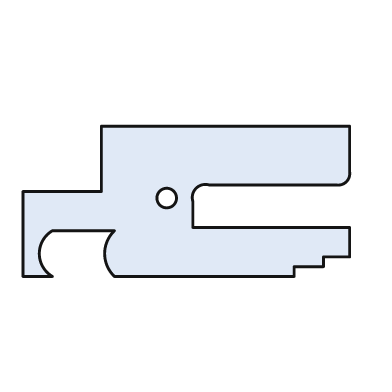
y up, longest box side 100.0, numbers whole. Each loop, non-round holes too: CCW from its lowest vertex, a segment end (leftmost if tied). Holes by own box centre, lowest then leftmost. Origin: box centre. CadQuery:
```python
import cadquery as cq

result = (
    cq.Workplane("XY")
    .moveTo(-50.0, -23.0)
    .lineTo(-41.0, -23.0)
    .threePointArc((-45.0, -16.0), (-41.0, -9.0))
    .lineTo(-22.0, -9.0)
    .threePointArc((-25.0, -16.0), (-22.0, -23.0))
    .lineTo(33.0, -23.0)
    .lineTo(33.0, -20.0)
    .lineTo(42.0, -20.0)
    .lineTo(42.0, -17.0)
    .lineTo(50.0, -17.0)
    .lineTo(50.0, -8.0)
    .lineTo(2.0, -8.0)
    .lineTo(2.0, 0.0)
    .threePointArc((3.0, 4.0), (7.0, 5.0))
    .lineTo(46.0, 5.0)
    .threePointArc((49.0, 6.0), (50.0, 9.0))
    .lineTo(50.0, 23.0)
    .lineTo(-26.0, 23.0)
    .lineTo(-26.0, 3.0)
    .lineTo(-50.0, 3.0)
    .close()
    .moveTo(-6.0, 1.0)
    .circle(3.0)
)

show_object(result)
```